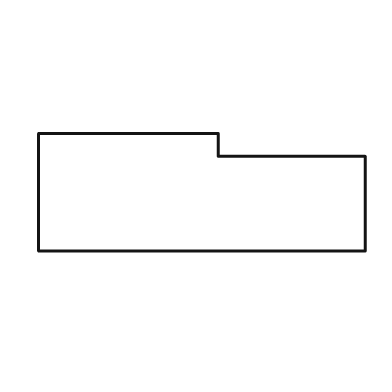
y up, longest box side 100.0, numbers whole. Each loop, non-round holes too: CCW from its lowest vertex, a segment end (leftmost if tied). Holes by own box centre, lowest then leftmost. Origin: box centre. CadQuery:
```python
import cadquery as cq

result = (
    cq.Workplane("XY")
    .moveTo(-50.0, -18.0)
    .lineTo(50.0, -18.0)
    .lineTo(50.0, 11.0)
    .lineTo(5.0, 11.0)
    .lineTo(5.0, 18.0)
    .lineTo(-50.0, 18.0)
    .close()
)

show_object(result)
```